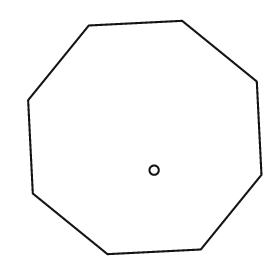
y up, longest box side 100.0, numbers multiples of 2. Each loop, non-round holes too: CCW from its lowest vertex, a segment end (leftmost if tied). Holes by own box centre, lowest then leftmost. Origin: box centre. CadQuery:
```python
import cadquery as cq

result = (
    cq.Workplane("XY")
    .moveTo(-16.0, -50.0)
    .lineTo(24.0, -48.0)
    .lineTo(50.0, -16.0)
    .lineTo(48.0, 24.0)
    .lineTo(16.0, 50.0)
    .lineTo(-24.0, 48.0)
    .lineTo(-50.0, 16.0)
    .lineTo(-48.0, -24.0)
    .close()
    .moveTo(4.0, -14.0)
    .circle(2.0)
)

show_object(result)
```